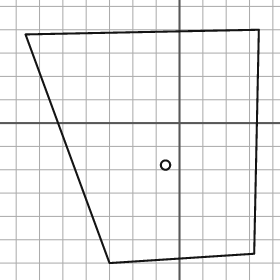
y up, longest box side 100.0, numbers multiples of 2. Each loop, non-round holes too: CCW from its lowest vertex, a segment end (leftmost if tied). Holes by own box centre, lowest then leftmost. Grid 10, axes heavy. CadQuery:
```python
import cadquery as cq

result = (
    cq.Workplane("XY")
    .moveTo(-30.0, -60.0)
    .lineTo(32.0, -56.0)
    .lineTo(34.0, 40.0)
    .lineTo(-66.0, 38.0)
    .close()
    .moveTo(-6.0, -18.0)
    .circle(2.0)
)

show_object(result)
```